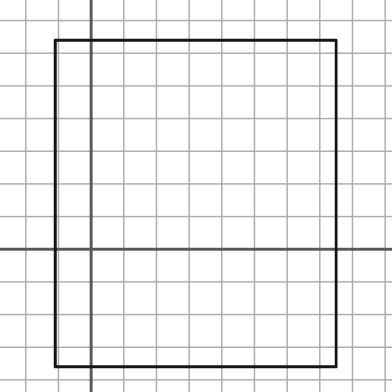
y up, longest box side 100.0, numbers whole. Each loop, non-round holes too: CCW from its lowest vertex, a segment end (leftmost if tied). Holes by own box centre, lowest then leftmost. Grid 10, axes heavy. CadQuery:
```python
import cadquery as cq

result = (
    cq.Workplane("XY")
    .moveTo(-11.0, -36.0)
    .lineTo(75.0, -36.0)
    .lineTo(75.0, 64.0)
    .lineTo(-11.0, 64.0)
    .close()
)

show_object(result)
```